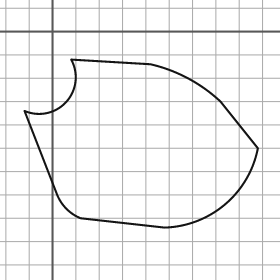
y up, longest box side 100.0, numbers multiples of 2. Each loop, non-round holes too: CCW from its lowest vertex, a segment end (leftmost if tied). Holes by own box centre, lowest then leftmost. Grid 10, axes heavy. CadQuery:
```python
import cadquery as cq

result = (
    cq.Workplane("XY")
    .moveTo(48.0, -84.0)
    .threePointArc((74.0, -74.0), (88.0, -50.0))
    .lineTo(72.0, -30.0)
    .threePointArc((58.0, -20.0), (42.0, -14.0))
    .lineTo(8.0, -12.0)
    .threePointArc((6.0, -30.0), (-12.0, -34.0))
    .lineTo(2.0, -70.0)
    .threePointArc((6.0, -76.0), (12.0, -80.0))
    .close()
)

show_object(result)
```